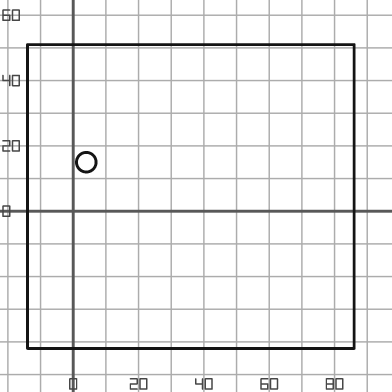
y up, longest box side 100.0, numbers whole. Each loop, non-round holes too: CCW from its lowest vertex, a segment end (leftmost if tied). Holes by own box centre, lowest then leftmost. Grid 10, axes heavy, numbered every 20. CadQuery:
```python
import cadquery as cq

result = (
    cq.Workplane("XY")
    .moveTo(-14.0, -42.0)
    .lineTo(86.0, -42.0)
    .lineTo(86.0, 51.0)
    .lineTo(-14.0, 51.0)
    .close()
    .moveTo(4.0, 15.0)
    .circle(3.0)
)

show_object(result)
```